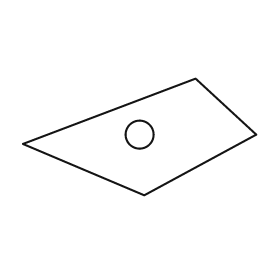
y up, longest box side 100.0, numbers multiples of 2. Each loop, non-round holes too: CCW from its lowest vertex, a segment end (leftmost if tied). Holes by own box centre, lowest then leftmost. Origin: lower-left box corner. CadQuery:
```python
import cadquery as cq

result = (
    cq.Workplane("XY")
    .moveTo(52.0, 0.0)
    .lineTo(100.0, 26.0)
    .lineTo(74.0, 50.0)
    .lineTo(0.0, 22.0)
    .close()
    .moveTo(50.0, 26.0)
    .circle(6.0)
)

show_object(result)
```